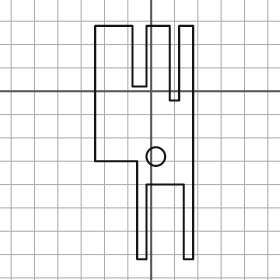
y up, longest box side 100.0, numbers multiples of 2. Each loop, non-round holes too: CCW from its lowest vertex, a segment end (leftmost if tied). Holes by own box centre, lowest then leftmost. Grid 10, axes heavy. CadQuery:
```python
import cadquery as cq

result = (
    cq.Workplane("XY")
    .moveTo(-6.0, -72.0)
    .lineTo(-2.0, -72.0)
    .lineTo(-2.0, -40.0)
    .lineTo(14.0, -40.0)
    .lineTo(14.0, -72.0)
    .lineTo(18.0, -72.0)
    .lineTo(18.0, 28.0)
    .lineTo(12.0, 28.0)
    .lineTo(12.0, -4.0)
    .lineTo(8.0, -4.0)
    .lineTo(8.0, 28.0)
    .lineTo(-2.0, 28.0)
    .lineTo(-2.0, 2.0)
    .lineTo(-8.0, 2.0)
    .lineTo(-8.0, 28.0)
    .lineTo(-24.0, 28.0)
    .lineTo(-24.0, -30.0)
    .lineTo(-6.0, -30.0)
    .close()
    .moveTo(2.0, -28.0)
    .circle(4.0)
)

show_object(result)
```